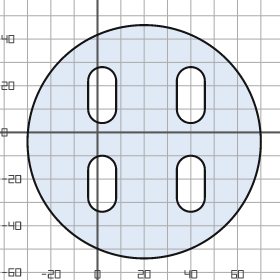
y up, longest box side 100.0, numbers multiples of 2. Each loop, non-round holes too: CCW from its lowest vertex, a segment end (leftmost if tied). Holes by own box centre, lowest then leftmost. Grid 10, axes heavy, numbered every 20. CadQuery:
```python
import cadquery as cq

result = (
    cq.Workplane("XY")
    .moveTo(20.0, -4.0)
    .circle(50.0)
    .moveTo(-4.0, -28.0)
    .threePointArc((2.0, -34.0), (8.0, -28.0))
    .lineTo(8.0, -16.0)
    .threePointArc((2.0, -10.0), (-4.0, -16.0))
    .close()
    .moveTo(34.0, -28.0)
    .threePointArc((40.0, -34.0), (46.0, -28.0))
    .lineTo(46.0, -16.0)
    .threePointArc((40.0, -10.0), (34.0, -16.0))
    .close()
    .moveTo(-4.0, 10.0)
    .threePointArc((2.0, 4.0), (8.0, 10.0))
    .lineTo(8.0, 22.0)
    .threePointArc((2.0, 28.0), (-4.0, 22.0))
    .close()
    .moveTo(34.0, 10.0)
    .threePointArc((40.0, 4.0), (46.0, 10.0))
    .lineTo(46.0, 22.0)
    .threePointArc((40.0, 28.0), (34.0, 22.0))
    .close()
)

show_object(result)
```